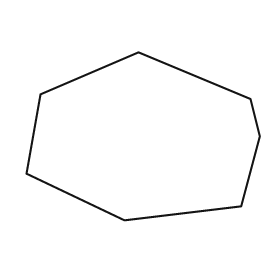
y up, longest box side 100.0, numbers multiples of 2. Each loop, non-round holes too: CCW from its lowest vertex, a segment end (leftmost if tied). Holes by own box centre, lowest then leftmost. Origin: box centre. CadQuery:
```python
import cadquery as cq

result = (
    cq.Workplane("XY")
    .moveTo(-8.0, -36.0)
    .lineTo(42.0, -30.0)
    .lineTo(50.0, 0.0)
    .lineTo(46.0, 16.0)
    .lineTo(-2.0, 36.0)
    .lineTo(-44.0, 18.0)
    .lineTo(-50.0, -16.0)
    .close()
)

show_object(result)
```